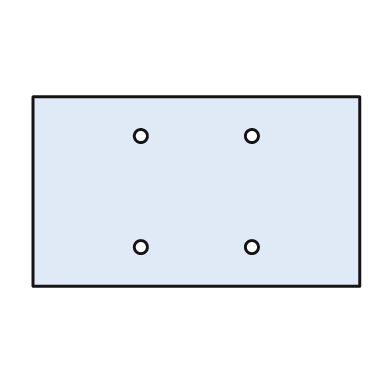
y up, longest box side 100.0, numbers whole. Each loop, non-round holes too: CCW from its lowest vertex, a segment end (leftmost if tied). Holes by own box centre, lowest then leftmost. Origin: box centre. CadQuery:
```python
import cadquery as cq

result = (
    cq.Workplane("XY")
    .moveTo(-50.0, -29.0)
    .lineTo(50.0, -29.0)
    .lineTo(50.0, 29.0)
    .lineTo(-50.0, 29.0)
    .close()
    .moveTo(-17.0, -17.0)
    .circle(2.0)
    .moveTo(17.0, -17.0)
    .circle(2.0)
    .moveTo(-17.0, 17.0)
    .circle(2.0)
    .moveTo(17.0, 17.0)
    .circle(2.0)
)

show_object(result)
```